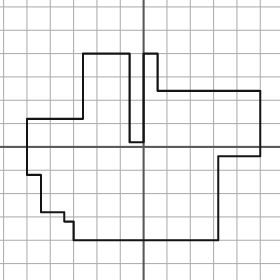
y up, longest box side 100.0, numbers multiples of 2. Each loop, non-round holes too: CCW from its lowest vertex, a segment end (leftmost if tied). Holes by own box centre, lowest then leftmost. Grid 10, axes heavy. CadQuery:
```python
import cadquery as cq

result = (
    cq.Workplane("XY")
    .moveTo(-30.0, -40.0)
    .lineTo(32.0, -40.0)
    .lineTo(32.0, -4.0)
    .lineTo(50.0, -4.0)
    .lineTo(50.0, 24.0)
    .lineTo(6.0, 24.0)
    .lineTo(6.0, 40.0)
    .lineTo(0.0, 40.0)
    .lineTo(0.0, 2.0)
    .lineTo(-6.0, 2.0)
    .lineTo(-6.0, 40.0)
    .lineTo(-26.0, 40.0)
    .lineTo(-26.0, 12.0)
    .lineTo(-50.0, 12.0)
    .lineTo(-50.0, -12.0)
    .lineTo(-44.0, -12.0)
    .lineTo(-44.0, -28.0)
    .lineTo(-34.0, -28.0)
    .lineTo(-34.0, -32.0)
    .lineTo(-30.0, -32.0)
    .close()
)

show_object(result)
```